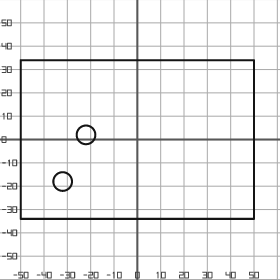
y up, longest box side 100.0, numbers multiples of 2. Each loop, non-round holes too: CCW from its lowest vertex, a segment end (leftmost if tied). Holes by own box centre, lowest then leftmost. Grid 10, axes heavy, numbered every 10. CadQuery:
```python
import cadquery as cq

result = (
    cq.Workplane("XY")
    .moveTo(-50.0, -34.0)
    .lineTo(50.0, -34.0)
    .lineTo(50.0, 34.0)
    .lineTo(-50.0, 34.0)
    .close()
    .moveTo(-32.0, -18.0)
    .circle(4.0)
    .moveTo(-22.0, 2.0)
    .circle(4.0)
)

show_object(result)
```